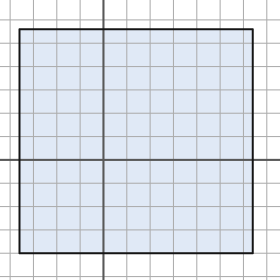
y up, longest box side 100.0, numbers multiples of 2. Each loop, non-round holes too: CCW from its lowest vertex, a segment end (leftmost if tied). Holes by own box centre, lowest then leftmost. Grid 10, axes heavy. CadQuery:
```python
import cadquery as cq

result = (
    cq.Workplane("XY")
    .moveTo(-36.0, -40.0)
    .lineTo(64.0, -40.0)
    .lineTo(64.0, 56.0)
    .lineTo(-36.0, 56.0)
    .close()
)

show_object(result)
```